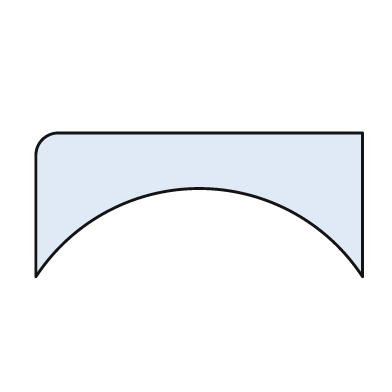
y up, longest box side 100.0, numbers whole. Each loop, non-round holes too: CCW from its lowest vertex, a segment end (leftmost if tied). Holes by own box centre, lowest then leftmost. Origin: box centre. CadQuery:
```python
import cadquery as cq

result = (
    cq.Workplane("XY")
    .moveTo(-50.0, -22.0)
    .threePointArc((0.0, 5.0), (50.0, -22.0))
    .lineTo(50.0, 22.0)
    .lineTo(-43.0, 22.0)
    .threePointArc((-48.0, 20.0), (-50.0, 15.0))
    .close()
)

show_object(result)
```